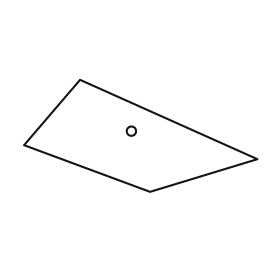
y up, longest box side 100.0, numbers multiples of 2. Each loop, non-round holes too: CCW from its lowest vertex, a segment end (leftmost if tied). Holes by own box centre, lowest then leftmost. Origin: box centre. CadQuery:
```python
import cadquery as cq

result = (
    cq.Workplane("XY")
    .moveTo(4.0, -24.0)
    .lineTo(50.0, -10.0)
    .lineTo(-26.0, 24.0)
    .lineTo(-50.0, -4.0)
    .close()
    .moveTo(-4.0, 2.0)
    .circle(2.0)
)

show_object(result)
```